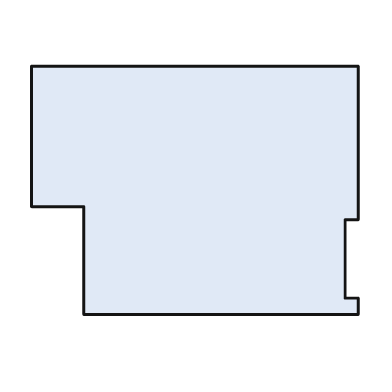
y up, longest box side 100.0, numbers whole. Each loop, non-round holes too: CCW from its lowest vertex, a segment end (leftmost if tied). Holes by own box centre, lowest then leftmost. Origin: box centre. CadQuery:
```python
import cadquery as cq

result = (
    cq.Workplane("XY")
    .moveTo(-34.0, -38.0)
    .lineTo(50.0, -38.0)
    .lineTo(50.0, -33.0)
    .lineTo(46.0, -33.0)
    .lineTo(46.0, -9.0)
    .lineTo(50.0, -9.0)
    .lineTo(50.0, 38.0)
    .lineTo(-50.0, 38.0)
    .lineTo(-50.0, -5.0)
    .lineTo(-34.0, -5.0)
    .close()
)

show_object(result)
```